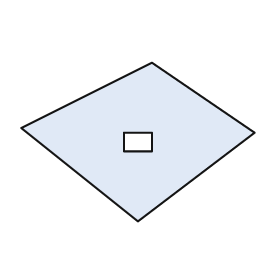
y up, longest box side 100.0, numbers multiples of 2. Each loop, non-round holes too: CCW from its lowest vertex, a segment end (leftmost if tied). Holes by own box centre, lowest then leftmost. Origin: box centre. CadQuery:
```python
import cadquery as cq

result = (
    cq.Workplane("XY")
    .moveTo(0.0, -34.0)
    .lineTo(50.0, 4.0)
    .lineTo(6.0, 34.0)
    .lineTo(-50.0, 6.0)
    .close()
    .moveTo(-6.0, -4.0)
    .lineTo(6.0, -4.0)
    .lineTo(6.0, 4.0)
    .lineTo(-6.0, 4.0)
    .close()
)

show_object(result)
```